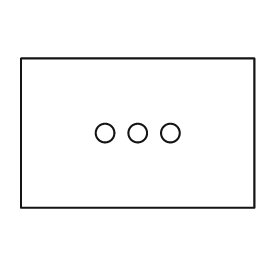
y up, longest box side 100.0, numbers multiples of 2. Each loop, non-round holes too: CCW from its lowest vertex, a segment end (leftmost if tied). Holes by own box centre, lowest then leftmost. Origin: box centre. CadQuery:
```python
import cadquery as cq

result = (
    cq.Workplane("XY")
    .moveTo(-50.0, -32.0)
    .lineTo(50.0, -32.0)
    .lineTo(50.0, 32.0)
    .lineTo(-50.0, 32.0)
    .close()
    .moveTo(-14.0, 0.0)
    .circle(4.0)
    .moveTo(0.0, 0.0)
    .circle(4.0)
    .moveTo(14.0, 0.0)
    .circle(4.0)
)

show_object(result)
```